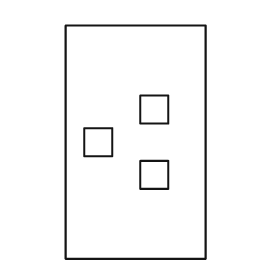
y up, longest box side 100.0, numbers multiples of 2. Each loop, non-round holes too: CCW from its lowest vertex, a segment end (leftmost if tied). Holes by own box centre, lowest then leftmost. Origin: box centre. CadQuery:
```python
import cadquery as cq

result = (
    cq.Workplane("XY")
    .moveTo(-30.0, -50.0)
    .lineTo(30.0, -50.0)
    .lineTo(30.0, 50.0)
    .lineTo(-30.0, 50.0)
    .close()
    .moveTo(2.0, -20.0)
    .lineTo(14.0, -20.0)
    .lineTo(14.0, -8.0)
    .lineTo(2.0, -8.0)
    .close()
    .moveTo(-22.0, -6.0)
    .lineTo(-10.0, -6.0)
    .lineTo(-10.0, 6.0)
    .lineTo(-22.0, 6.0)
    .close()
    .moveTo(2.0, 8.0)
    .lineTo(14.0, 8.0)
    .lineTo(14.0, 20.0)
    .lineTo(2.0, 20.0)
    .close()
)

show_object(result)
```